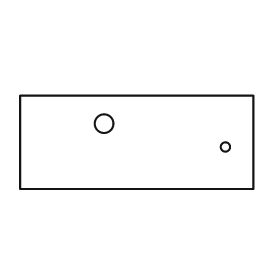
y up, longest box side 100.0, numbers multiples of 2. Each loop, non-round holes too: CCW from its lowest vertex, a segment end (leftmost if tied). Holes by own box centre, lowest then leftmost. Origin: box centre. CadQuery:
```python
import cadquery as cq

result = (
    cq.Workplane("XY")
    .moveTo(-50.0, -20.0)
    .lineTo(50.0, -20.0)
    .lineTo(50.0, 20.0)
    .lineTo(-50.0, 20.0)
    .close()
    .moveTo(38.0, -2.0)
    .circle(2.0)
    .moveTo(-14.0, 8.0)
    .circle(4.0)
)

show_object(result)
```